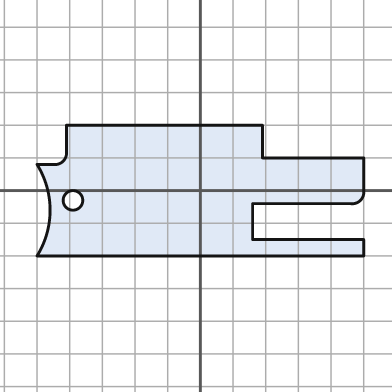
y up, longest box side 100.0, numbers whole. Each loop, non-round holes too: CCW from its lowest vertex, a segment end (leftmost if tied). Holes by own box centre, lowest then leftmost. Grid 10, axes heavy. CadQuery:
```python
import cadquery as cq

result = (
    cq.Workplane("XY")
    .moveTo(-50.0, -20.0)
    .lineTo(50.0, -20.0)
    .lineTo(50.0, -15.0)
    .lineTo(16.0, -15.0)
    .lineTo(16.0, -4.0)
    .lineTo(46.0, -4.0)
    .threePointArc((49.0, -3.0), (50.0, 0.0))
    .lineTo(50.0, 10.0)
    .lineTo(19.0, 10.0)
    .lineTo(19.0, 20.0)
    .lineTo(-41.0, 20.0)
    .lineTo(-41.0, 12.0)
    .threePointArc((-42.0, 9.0), (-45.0, 8.0))
    .lineTo(-50.0, 8.0)
    .threePointArc((-46.0, -6.0), (-50.0, -20.0))
    .close()
    .moveTo(-39.0, -3.0)
    .circle(3.0)
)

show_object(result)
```